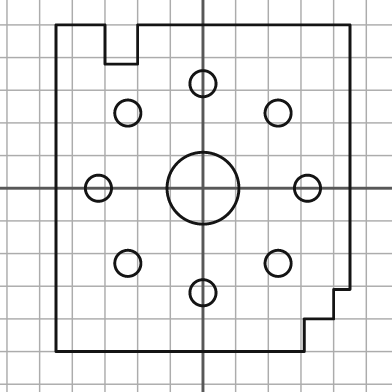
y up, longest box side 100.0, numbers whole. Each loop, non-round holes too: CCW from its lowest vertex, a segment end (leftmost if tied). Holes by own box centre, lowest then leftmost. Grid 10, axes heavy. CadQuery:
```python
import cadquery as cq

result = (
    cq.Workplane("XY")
    .moveTo(-45.0, -50.0)
    .lineTo(31.0, -50.0)
    .lineTo(31.0, -40.0)
    .lineTo(40.0, -40.0)
    .lineTo(40.0, -31.0)
    .lineTo(45.0, -31.0)
    .lineTo(45.0, 50.0)
    .lineTo(-20.0, 50.0)
    .lineTo(-20.0, 38.0)
    .lineTo(-30.0, 38.0)
    .lineTo(-30.0, 50.0)
    .lineTo(-45.0, 50.0)
    .close()
    .moveTo(0.0, -32.0)
    .circle(4.0)
    .moveTo(-23.0, -23.0)
    .circle(4.0)
    .moveTo(23.0, -23.0)
    .circle(4.0)
    .moveTo(-32.0, 0.0)
    .circle(4.0)
    .moveTo(0.0, 0.0)
    .circle(11.0)
    .moveTo(32.0, 0.0)
    .circle(4.0)
    .moveTo(-23.0, 23.0)
    .circle(4.0)
    .moveTo(23.0, 23.0)
    .circle(4.0)
    .moveTo(0.0, 32.0)
    .circle(4.0)
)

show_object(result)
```